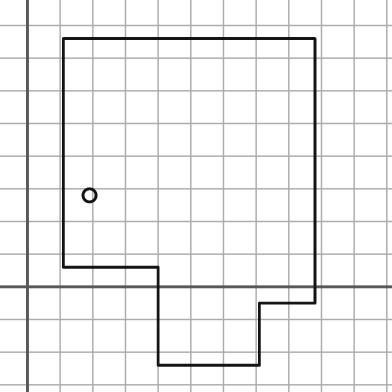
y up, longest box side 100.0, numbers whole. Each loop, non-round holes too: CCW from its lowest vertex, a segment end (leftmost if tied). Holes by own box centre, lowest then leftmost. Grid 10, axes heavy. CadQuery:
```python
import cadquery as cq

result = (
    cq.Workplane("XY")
    .moveTo(40.0, -24.0)
    .lineTo(71.0, -24.0)
    .lineTo(71.0, -5.0)
    .lineTo(88.0, -5.0)
    .lineTo(88.0, 76.0)
    .lineTo(11.0, 76.0)
    .lineTo(11.0, 6.0)
    .lineTo(40.0, 6.0)
    .close()
    .moveTo(19.0, 28.0)
    .circle(2.0)
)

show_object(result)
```